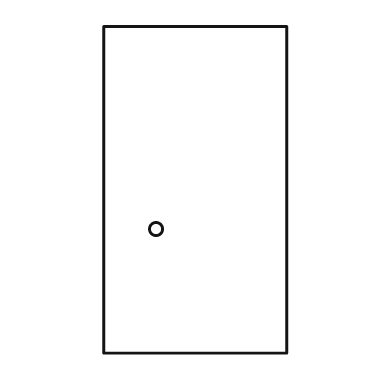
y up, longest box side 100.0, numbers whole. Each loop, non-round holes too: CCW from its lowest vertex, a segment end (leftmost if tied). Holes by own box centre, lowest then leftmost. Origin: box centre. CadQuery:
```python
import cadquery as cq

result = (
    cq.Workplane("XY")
    .moveTo(-28.0, -50.0)
    .lineTo(28.0, -50.0)
    .lineTo(28.0, 50.0)
    .lineTo(-28.0, 50.0)
    .close()
    .moveTo(-12.0, -12.0)
    .circle(2.0)
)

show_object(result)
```